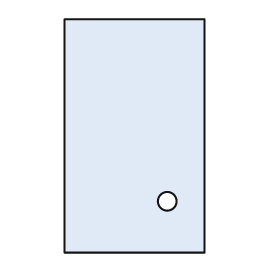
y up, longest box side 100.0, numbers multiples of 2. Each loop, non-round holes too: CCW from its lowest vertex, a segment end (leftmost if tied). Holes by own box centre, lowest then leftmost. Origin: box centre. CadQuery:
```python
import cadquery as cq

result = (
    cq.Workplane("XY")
    .moveTo(-30.0, -50.0)
    .lineTo(30.0, -50.0)
    .lineTo(30.0, 50.0)
    .lineTo(-30.0, 50.0)
    .close()
    .moveTo(14.0, -28.0)
    .circle(4.0)
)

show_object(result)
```